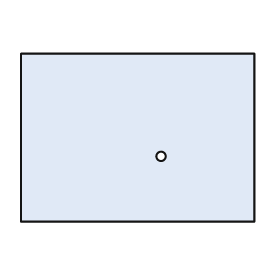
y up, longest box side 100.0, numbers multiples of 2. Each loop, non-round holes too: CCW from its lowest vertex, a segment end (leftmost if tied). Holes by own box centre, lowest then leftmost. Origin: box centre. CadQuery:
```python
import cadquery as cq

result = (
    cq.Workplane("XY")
    .moveTo(-50.0, -36.0)
    .lineTo(50.0, -36.0)
    .lineTo(50.0, 36.0)
    .lineTo(-50.0, 36.0)
    .close()
    .moveTo(10.0, -8.0)
    .circle(2.0)
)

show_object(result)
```